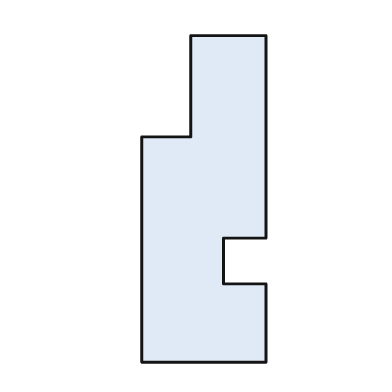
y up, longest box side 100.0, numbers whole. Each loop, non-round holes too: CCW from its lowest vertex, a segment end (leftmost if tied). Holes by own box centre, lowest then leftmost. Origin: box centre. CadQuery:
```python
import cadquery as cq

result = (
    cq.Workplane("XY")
    .moveTo(-19.0, -50.0)
    .lineTo(19.0, -50.0)
    .lineTo(19.0, -26.0)
    .lineTo(6.0, -26.0)
    .lineTo(6.0, -12.0)
    .lineTo(19.0, -12.0)
    .lineTo(19.0, 50.0)
    .lineTo(-4.0, 50.0)
    .lineTo(-4.0, 19.0)
    .lineTo(-19.0, 19.0)
    .close()
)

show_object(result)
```